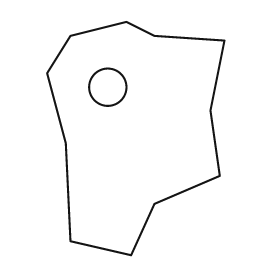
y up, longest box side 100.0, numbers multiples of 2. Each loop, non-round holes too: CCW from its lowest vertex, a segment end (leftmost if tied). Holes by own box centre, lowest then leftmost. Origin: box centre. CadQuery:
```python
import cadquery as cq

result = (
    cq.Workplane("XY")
    .moveTo(-2.0, -50.0)
    .lineTo(8.0, -28.0)
    .lineTo(36.0, -16.0)
    .lineTo(32.0, 12.0)
    .lineTo(38.0, 42.0)
    .lineTo(8.0, 44.0)
    .lineTo(-4.0, 50.0)
    .lineTo(-28.0, 44.0)
    .lineTo(-38.0, 28.0)
    .lineTo(-30.0, -2.0)
    .lineTo(-28.0, -44.0)
    .close()
    .moveTo(-12.0, 22.0)
    .circle(8.0)
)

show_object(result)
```